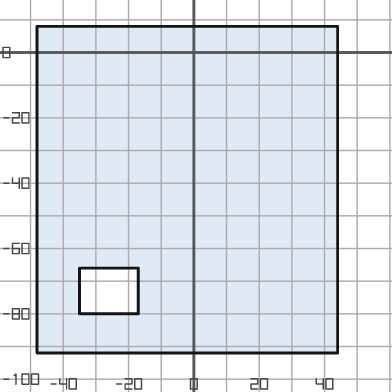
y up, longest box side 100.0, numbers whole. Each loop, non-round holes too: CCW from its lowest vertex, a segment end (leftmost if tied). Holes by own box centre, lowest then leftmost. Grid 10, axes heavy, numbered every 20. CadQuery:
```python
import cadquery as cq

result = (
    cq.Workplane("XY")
    .moveTo(-48.0, -92.0)
    .lineTo(44.0, -92.0)
    .lineTo(44.0, 8.0)
    .lineTo(-48.0, 8.0)
    .close()
    .moveTo(-35.0, -80.0)
    .lineTo(-17.0, -80.0)
    .lineTo(-17.0, -66.0)
    .lineTo(-35.0, -66.0)
    .close()
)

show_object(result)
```